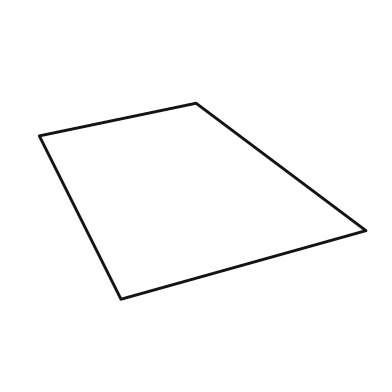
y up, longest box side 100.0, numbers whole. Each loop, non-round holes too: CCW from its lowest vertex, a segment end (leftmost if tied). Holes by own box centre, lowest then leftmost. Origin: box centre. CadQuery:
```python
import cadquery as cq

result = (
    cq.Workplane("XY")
    .moveTo(-25.0, -30.0)
    .lineTo(50.0, -9.0)
    .lineTo(-2.0, 30.0)
    .lineTo(-50.0, 20.0)
    .close()
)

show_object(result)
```